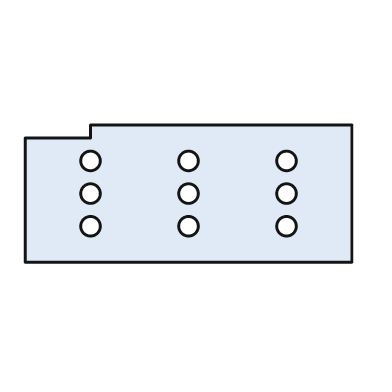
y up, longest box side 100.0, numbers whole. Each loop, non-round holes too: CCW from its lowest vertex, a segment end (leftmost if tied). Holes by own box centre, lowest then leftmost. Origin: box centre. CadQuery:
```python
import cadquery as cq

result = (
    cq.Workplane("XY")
    .moveTo(-50.0, -21.0)
    .lineTo(50.0, -21.0)
    .lineTo(50.0, 21.0)
    .lineTo(-30.0, 21.0)
    .lineTo(-30.0, 17.0)
    .lineTo(-50.0, 17.0)
    .close()
    .moveTo(-30.0, -10.0)
    .circle(3.0)
    .moveTo(0.0, -10.0)
    .circle(3.0)
    .moveTo(30.0, -10.0)
    .circle(3.0)
    .moveTo(-30.0, 0.0)
    .circle(3.0)
    .moveTo(0.0, 0.0)
    .circle(3.0)
    .moveTo(30.0, 0.0)
    .circle(3.0)
    .moveTo(-30.0, 10.0)
    .circle(3.0)
    .moveTo(0.0, 10.0)
    .circle(3.0)
    .moveTo(30.0, 10.0)
    .circle(3.0)
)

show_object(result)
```